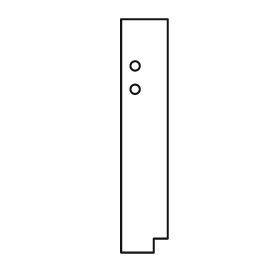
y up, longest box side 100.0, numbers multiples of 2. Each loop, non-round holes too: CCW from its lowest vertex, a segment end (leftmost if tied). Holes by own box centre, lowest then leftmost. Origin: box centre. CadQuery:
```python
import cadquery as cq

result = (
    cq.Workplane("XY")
    .moveTo(-10.0, -50.0)
    .lineTo(4.0, -50.0)
    .lineTo(4.0, -44.0)
    .lineTo(10.0, -44.0)
    .lineTo(10.0, 50.0)
    .lineTo(-10.0, 50.0)
    .close()
    .moveTo(-4.0, 20.0)
    .circle(2.0)
    .moveTo(-4.0, 30.0)
    .circle(2.0)
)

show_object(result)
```